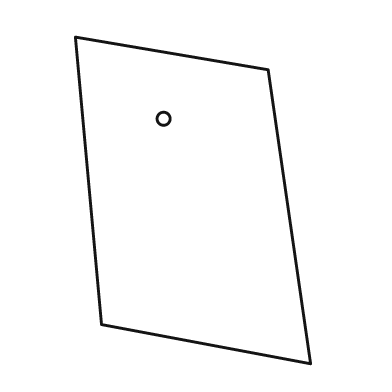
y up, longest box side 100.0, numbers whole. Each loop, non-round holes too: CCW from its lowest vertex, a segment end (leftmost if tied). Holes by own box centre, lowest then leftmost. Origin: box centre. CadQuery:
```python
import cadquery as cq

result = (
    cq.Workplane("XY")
    .moveTo(36.0, -50.0)
    .lineTo(23.0, 40.0)
    .lineTo(-36.0, 50.0)
    .lineTo(-28.0, -38.0)
    .close()
    .moveTo(-9.0, 25.0)
    .circle(2.0)
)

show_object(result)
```